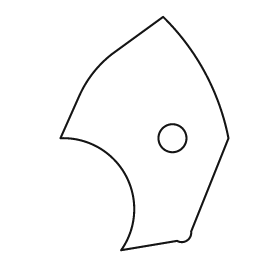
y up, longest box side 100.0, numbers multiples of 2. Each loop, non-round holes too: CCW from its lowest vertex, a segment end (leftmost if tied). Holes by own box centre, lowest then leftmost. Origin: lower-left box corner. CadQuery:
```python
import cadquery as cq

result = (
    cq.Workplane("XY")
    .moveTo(26.0, 0.0)
    .lineTo(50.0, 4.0)
    .threePointArc((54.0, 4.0), (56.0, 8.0))
    .lineTo(72.0, 48.0)
    .threePointArc((62.0, 76.0), (44.0, 100.0))
    .lineTo(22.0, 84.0)
    .threePointArc((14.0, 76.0), (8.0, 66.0))
    .lineTo(0.0, 48.0)
    .threePointArc((28.0, 32.0), (26.0, 0.0))
    .close()
    .moveTo(48.0, 48.0)
    .circle(6.0)
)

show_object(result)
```